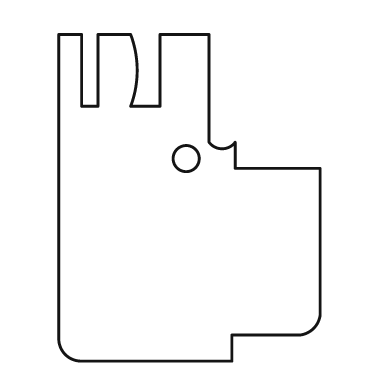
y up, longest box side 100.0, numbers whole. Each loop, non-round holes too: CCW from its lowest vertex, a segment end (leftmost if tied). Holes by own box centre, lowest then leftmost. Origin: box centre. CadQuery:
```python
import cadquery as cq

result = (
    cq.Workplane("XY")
    .moveTo(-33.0, -50.0)
    .lineTo(13.0, -50.0)
    .lineTo(13.0, -42.0)
    .lineTo(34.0, -42.0)
    .threePointArc((38.0, -40.0), (40.0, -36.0))
    .lineTo(40.0, 9.0)
    .lineTo(14.0, 9.0)
    .lineTo(14.0, 17.0)
    .threePointArc((10.0, 15.0), (6.0, 17.0))
    .lineTo(6.0, 50.0)
    .lineTo(-9.0, 50.0)
    .lineTo(-9.0, 28.0)
    .lineTo(-18.0, 28.0)
    .threePointArc((-16.0, 39.0), (-18.0, 50.0))
    .lineTo(-28.0, 50.0)
    .lineTo(-28.0, 28.0)
    .lineTo(-33.0, 28.0)
    .lineTo(-33.0, 50.0)
    .lineTo(-40.0, 50.0)
    .lineTo(-40.0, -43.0)
    .threePointArc((-38.0, -48.0), (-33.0, -50.0))
    .close()
    .moveTo(-1.0, 12.0)
    .circle(4.0)
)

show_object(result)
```